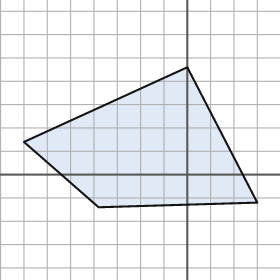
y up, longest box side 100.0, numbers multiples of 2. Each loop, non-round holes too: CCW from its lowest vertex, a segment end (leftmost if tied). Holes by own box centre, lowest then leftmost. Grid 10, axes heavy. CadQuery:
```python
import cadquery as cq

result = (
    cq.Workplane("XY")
    .moveTo(-38.0, -14.0)
    .lineTo(30.0, -12.0)
    .lineTo(0.0, 46.0)
    .lineTo(-70.0, 14.0)
    .close()
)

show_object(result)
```